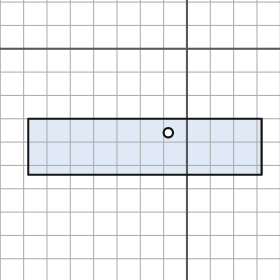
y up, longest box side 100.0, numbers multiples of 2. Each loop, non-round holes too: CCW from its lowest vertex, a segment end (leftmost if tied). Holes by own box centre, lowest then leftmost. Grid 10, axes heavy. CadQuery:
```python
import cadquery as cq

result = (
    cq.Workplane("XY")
    .moveTo(-68.0, -54.0)
    .lineTo(32.0, -54.0)
    .lineTo(32.0, -30.0)
    .lineTo(-68.0, -30.0)
    .close()
    .moveTo(-8.0, -36.0)
    .circle(2.0)
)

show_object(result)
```